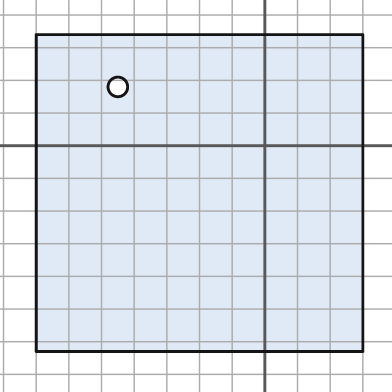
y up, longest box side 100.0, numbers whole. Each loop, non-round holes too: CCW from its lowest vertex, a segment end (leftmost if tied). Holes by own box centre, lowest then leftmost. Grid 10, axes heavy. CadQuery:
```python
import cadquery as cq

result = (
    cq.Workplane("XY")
    .moveTo(-70.0, -63.0)
    .lineTo(30.0, -63.0)
    .lineTo(30.0, 34.0)
    .lineTo(-70.0, 34.0)
    .close()
    .moveTo(-45.0, 18.0)
    .circle(3.0)
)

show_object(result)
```